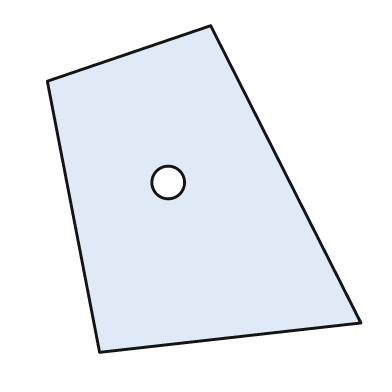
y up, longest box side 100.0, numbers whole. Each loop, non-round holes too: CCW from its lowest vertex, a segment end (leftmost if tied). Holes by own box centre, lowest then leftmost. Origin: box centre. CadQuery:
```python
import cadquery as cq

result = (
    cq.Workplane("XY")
    .moveTo(-32.0, -50.0)
    .lineTo(48.0, -41.0)
    .lineTo(2.0, 50.0)
    .lineTo(-48.0, 33.0)
    .close()
    .moveTo(-11.0, 2.0)
    .circle(5.0)
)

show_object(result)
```